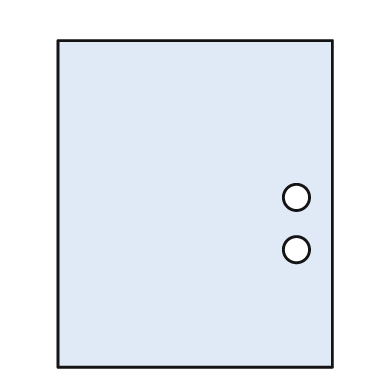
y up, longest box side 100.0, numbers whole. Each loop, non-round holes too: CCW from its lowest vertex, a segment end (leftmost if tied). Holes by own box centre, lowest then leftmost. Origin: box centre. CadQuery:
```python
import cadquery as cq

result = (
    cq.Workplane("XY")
    .moveTo(-42.0, -50.0)
    .lineTo(42.0, -50.0)
    .lineTo(42.0, 50.0)
    .lineTo(-42.0, 50.0)
    .close()
    .moveTo(31.0, -14.0)
    .circle(4.0)
    .moveTo(31.0, 2.0)
    .circle(4.0)
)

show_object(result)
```